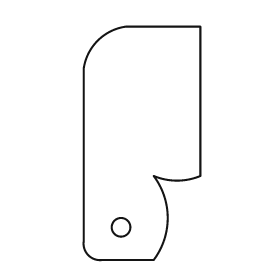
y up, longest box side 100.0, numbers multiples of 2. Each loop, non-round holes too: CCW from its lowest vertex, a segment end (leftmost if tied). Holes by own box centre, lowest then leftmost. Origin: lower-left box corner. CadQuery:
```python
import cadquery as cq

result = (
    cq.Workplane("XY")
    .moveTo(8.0, 0.0)
    .lineTo(30.0, 0.0)
    .threePointArc((36.0, 18.0), (30.0, 36.0))
    .threePointArc((40.0, 34.0), (50.0, 36.0))
    .lineTo(50.0, 100.0)
    .lineTo(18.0, 100.0)
    .threePointArc((6.0, 94.0), (0.0, 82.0))
    .lineTo(0.0, 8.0)
    .threePointArc((2.0, 2.0), (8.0, 0.0))
    .close()
    .moveTo(16.0, 14.0)
    .circle(4.0)
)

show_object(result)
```